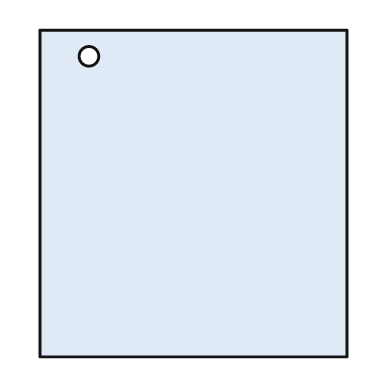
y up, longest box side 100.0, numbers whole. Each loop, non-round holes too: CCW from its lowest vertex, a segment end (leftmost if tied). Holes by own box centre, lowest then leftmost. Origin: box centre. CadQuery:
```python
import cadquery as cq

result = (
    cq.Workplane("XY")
    .moveTo(-47.0, -50.0)
    .lineTo(47.0, -50.0)
    .lineTo(47.0, 50.0)
    .lineTo(-47.0, 50.0)
    .close()
    .moveTo(-32.0, 42.0)
    .circle(3.0)
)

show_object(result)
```